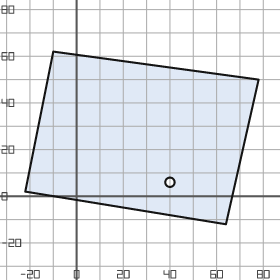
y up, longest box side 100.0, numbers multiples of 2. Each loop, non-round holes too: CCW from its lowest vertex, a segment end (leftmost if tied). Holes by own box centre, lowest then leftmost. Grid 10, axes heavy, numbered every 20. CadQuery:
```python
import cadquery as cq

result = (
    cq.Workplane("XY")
    .moveTo(64.0, -12.0)
    .lineTo(78.0, 50.0)
    .lineTo(-10.0, 62.0)
    .lineTo(-22.0, 2.0)
    .close()
    .moveTo(40.0, 6.0)
    .circle(2.0)
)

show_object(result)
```